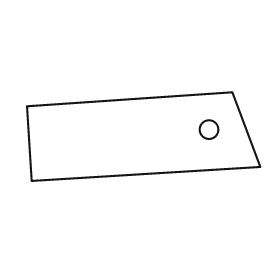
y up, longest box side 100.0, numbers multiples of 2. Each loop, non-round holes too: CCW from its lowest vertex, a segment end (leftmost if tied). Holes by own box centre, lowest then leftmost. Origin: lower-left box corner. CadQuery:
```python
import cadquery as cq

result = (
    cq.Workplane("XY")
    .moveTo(2.0, 0.0)
    .lineTo(100.0, 6.0)
    .lineTo(88.0, 38.0)
    .lineTo(0.0, 32.0)
    .close()
    .moveTo(78.0, 22.0)
    .circle(4.0)
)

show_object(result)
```